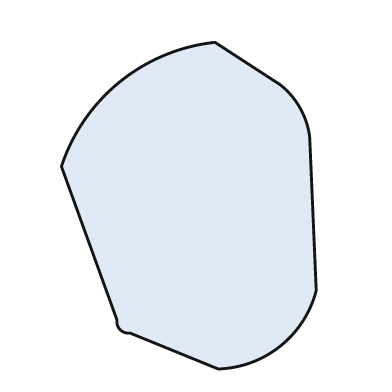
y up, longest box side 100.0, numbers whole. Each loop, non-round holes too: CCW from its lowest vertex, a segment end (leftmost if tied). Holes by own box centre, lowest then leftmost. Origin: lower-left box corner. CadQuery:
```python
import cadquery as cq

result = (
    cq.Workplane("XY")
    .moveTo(48.0, 0.0)
    .threePointArc((67.0, 7.0), (78.0, 24.0))
    .lineTo(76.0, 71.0)
    .threePointArc((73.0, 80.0), (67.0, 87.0))
    .lineTo(47.0, 100.0)
    .threePointArc((18.0, 88.0), (0.0, 62.0))
    .lineTo(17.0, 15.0)
    .threePointArc((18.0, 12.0), (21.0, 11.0))
    .close()
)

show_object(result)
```